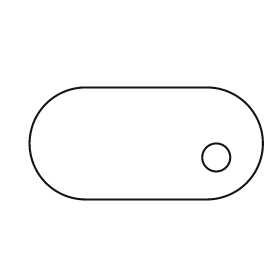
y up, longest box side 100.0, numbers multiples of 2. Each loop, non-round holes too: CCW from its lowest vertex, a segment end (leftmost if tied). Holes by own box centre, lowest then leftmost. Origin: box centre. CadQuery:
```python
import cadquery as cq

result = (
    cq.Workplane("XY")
    .moveTo(-26.0, -24.0)
    .lineTo(26.0, -24.0)
    .threePointArc((50.0, 0.0), (26.0, 24.0))
    .lineTo(-26.0, 24.0)
    .threePointArc((-50.0, 0.0), (-26.0, -24.0))
    .close()
    .moveTo(30.0, -6.0)
    .circle(6.0)
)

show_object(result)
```